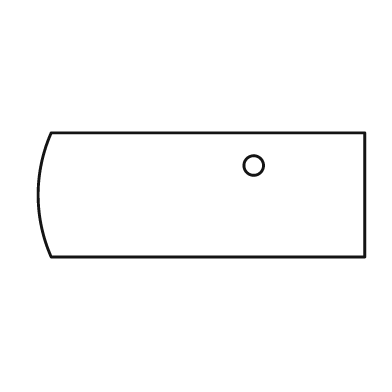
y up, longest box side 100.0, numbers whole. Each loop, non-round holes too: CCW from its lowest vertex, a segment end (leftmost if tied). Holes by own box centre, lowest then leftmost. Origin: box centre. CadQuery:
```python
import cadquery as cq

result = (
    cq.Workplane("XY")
    .moveTo(-46.0, -19.0)
    .lineTo(50.0, -19.0)
    .lineTo(50.0, 19.0)
    .lineTo(-46.0, 19.0)
    .threePointArc((-50.0, 0.0), (-46.0, -19.0))
    .close()
    .moveTo(16.0, 9.0)
    .circle(3.0)
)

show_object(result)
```